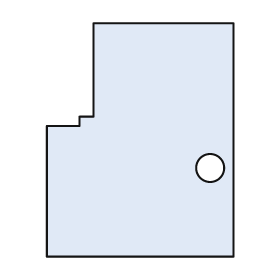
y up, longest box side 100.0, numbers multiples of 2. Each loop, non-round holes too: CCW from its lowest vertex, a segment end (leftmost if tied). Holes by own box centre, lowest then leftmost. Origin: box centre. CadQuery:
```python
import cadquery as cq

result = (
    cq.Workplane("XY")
    .moveTo(-40.0, -50.0)
    .lineTo(40.0, -50.0)
    .lineTo(40.0, 50.0)
    .lineTo(-20.0, 50.0)
    .lineTo(-20.0, 10.0)
    .lineTo(-26.0, 10.0)
    .lineTo(-26.0, 6.0)
    .lineTo(-40.0, 6.0)
    .close()
    .moveTo(30.0, -12.0)
    .circle(6.0)
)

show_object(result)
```